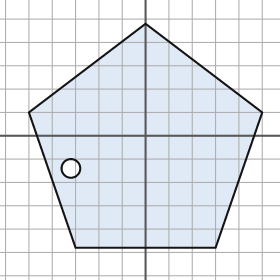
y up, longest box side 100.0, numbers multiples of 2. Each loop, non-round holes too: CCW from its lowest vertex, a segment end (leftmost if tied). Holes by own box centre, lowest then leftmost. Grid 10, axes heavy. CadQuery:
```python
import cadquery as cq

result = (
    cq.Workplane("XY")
    .moveTo(-30.0, -48.0)
    .lineTo(30.0, -48.0)
    .lineTo(50.0, 10.0)
    .lineTo(0.0, 48.0)
    .lineTo(-50.0, 10.0)
    .close()
    .moveTo(-32.0, -14.0)
    .circle(4.0)
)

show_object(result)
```